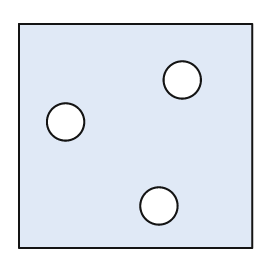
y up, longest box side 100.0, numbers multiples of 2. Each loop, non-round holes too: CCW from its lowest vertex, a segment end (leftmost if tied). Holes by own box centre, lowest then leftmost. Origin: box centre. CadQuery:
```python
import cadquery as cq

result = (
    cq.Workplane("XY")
    .moveTo(-50.0, -48.0)
    .lineTo(50.0, -48.0)
    .lineTo(50.0, 48.0)
    .lineTo(-50.0, 48.0)
    .close()
    .moveTo(10.0, -30.0)
    .circle(8.0)
    .moveTo(-30.0, 6.0)
    .circle(8.0)
    .moveTo(20.0, 24.0)
    .circle(8.0)
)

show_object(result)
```